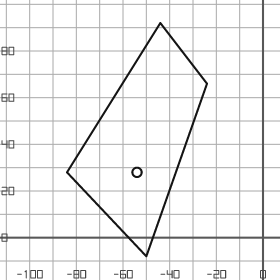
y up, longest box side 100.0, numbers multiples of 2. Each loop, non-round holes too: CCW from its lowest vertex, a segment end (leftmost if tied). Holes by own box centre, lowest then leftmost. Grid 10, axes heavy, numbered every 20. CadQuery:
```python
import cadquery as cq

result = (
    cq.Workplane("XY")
    .moveTo(-50.0, -8.0)
    .lineTo(-24.0, 66.0)
    .lineTo(-44.0, 92.0)
    .lineTo(-84.0, 28.0)
    .close()
    .moveTo(-54.0, 28.0)
    .circle(2.0)
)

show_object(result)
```